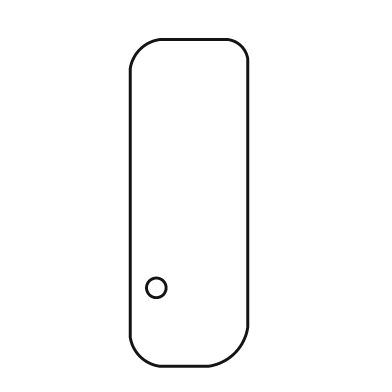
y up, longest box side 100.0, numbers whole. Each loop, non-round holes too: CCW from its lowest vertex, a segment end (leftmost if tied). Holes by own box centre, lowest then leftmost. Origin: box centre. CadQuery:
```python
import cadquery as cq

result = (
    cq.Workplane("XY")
    .moveTo(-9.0, -50.0)
    .lineTo(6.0, -50.0)
    .threePointArc((14.0, -46.0), (18.0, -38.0))
    .lineTo(18.0, 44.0)
    .threePointArc((16.0, 48.0), (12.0, 50.0))
    .lineTo(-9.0, 50.0)
    .threePointArc((-15.0, 47.0), (-18.0, 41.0))
    .lineTo(-18.0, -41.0)
    .threePointArc((-15.0, -47.0), (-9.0, -50.0))
    .close()
    .moveTo(-10.0, -26.0)
    .circle(3.0)
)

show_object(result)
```